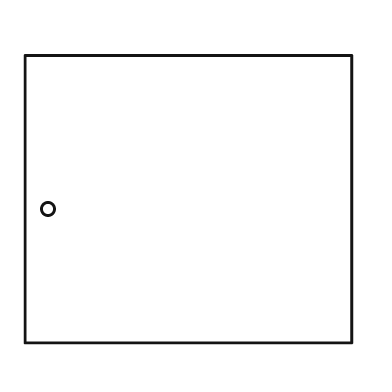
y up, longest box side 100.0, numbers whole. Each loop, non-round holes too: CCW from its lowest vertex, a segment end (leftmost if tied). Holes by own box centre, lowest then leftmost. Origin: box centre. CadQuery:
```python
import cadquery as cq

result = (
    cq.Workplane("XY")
    .moveTo(-50.0, -44.0)
    .lineTo(50.0, -44.0)
    .lineTo(50.0, 44.0)
    .lineTo(-50.0, 44.0)
    .close()
    .moveTo(-43.0, -3.0)
    .circle(2.0)
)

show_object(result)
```